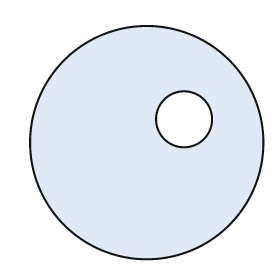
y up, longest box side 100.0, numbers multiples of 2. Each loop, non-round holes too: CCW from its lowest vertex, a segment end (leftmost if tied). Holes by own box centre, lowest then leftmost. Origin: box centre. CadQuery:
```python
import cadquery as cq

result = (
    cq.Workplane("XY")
    .moveTo(0.0, 0.0)
    .circle(50.0)
    .moveTo(16.0, 10.0)
    .circle(12.0)
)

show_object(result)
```